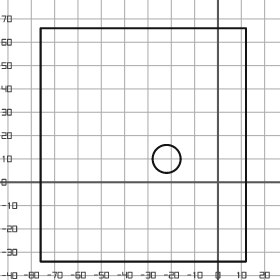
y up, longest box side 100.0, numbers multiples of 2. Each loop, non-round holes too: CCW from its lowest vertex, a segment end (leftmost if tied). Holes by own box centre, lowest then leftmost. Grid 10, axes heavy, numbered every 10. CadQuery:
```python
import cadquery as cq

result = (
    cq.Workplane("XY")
    .moveTo(-76.0, -34.0)
    .lineTo(12.0, -34.0)
    .lineTo(12.0, 66.0)
    .lineTo(-76.0, 66.0)
    .close()
    .moveTo(-22.0, 10.0)
    .circle(6.0)
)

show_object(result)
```